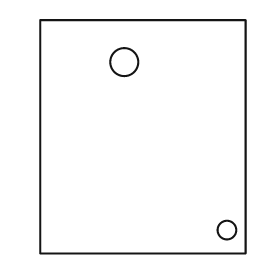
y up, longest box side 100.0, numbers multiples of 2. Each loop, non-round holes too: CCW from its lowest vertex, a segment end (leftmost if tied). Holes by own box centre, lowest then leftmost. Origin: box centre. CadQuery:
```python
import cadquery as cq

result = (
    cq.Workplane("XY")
    .moveTo(-44.0, -50.0)
    .lineTo(44.0, -50.0)
    .lineTo(44.0, 50.0)
    .lineTo(-44.0, 50.0)
    .close()
    .moveTo(36.0, -40.0)
    .circle(4.0)
    .moveTo(-8.0, 32.0)
    .circle(6.0)
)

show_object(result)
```